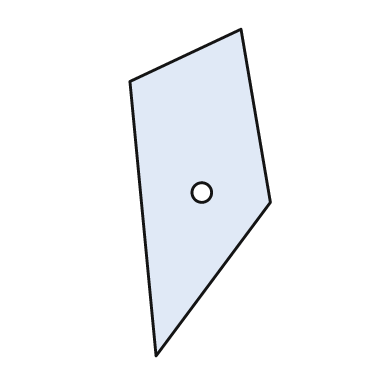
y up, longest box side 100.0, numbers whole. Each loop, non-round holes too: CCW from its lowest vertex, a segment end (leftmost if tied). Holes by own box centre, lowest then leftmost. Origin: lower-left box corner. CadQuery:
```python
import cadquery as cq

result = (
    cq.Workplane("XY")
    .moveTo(8.0, 0.0)
    .lineTo(43.0, 47.0)
    .lineTo(34.0, 100.0)
    .lineTo(0.0, 84.0)
    .close()
    .moveTo(22.0, 50.0)
    .circle(3.0)
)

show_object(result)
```